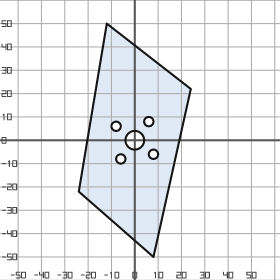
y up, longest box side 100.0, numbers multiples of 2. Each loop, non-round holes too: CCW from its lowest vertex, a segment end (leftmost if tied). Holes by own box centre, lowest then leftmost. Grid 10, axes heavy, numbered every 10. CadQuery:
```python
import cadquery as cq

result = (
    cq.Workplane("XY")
    .moveTo(8.0, -50.0)
    .lineTo(24.0, 22.0)
    .lineTo(-12.0, 50.0)
    .lineTo(-24.0, -22.0)
    .close()
    .moveTo(-6.0, -8.0)
    .circle(2.0)
    .moveTo(8.0, -6.0)
    .circle(2.0)
    .moveTo(0.0, 0.0)
    .circle(4.0)
    .moveTo(-8.0, 6.0)
    .circle(2.0)
    .moveTo(6.0, 8.0)
    .circle(2.0)
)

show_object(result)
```